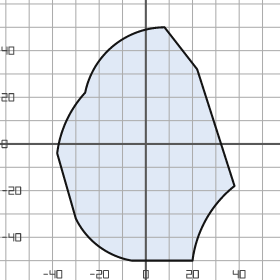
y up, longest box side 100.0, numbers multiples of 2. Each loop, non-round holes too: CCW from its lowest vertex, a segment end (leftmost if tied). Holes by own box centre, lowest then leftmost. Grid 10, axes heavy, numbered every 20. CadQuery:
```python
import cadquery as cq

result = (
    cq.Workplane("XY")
    .moveTo(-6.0, -50.0)
    .lineTo(20.0, -50.0)
    .threePointArc((26.0, -32.0), (38.0, -18.0))
    .lineTo(22.0, 32.0)
    .lineTo(8.0, 50.0)
    .threePointArc((-14.0, 42.0), (-26.0, 22.0))
    .threePointArc((-34.0, 10.0), (-38.0, -4.0))
    .lineTo(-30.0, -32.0)
    .threePointArc((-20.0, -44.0), (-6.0, -50.0))
    .close()
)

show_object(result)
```